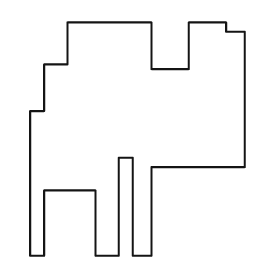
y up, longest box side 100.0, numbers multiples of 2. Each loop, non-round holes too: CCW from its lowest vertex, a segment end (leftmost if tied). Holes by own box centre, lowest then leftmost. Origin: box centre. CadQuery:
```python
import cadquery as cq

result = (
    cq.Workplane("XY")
    .moveTo(-46.0, -50.0)
    .lineTo(-40.0, -50.0)
    .lineTo(-40.0, -22.0)
    .lineTo(-18.0, -22.0)
    .lineTo(-18.0, -50.0)
    .lineTo(-8.0, -50.0)
    .lineTo(-8.0, -8.0)
    .lineTo(-2.0, -8.0)
    .lineTo(-2.0, -50.0)
    .lineTo(6.0, -50.0)
    .lineTo(6.0, -12.0)
    .lineTo(46.0, -12.0)
    .lineTo(46.0, 46.0)
    .lineTo(38.0, 46.0)
    .lineTo(38.0, 50.0)
    .lineTo(22.0, 50.0)
    .lineTo(22.0, 30.0)
    .lineTo(6.0, 30.0)
    .lineTo(6.0, 50.0)
    .lineTo(-30.0, 50.0)
    .lineTo(-30.0, 32.0)
    .lineTo(-40.0, 32.0)
    .lineTo(-40.0, 12.0)
    .lineTo(-46.0, 12.0)
    .close()
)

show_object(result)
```